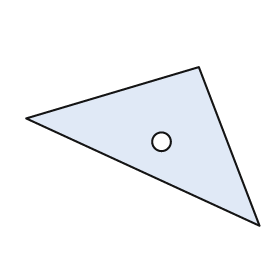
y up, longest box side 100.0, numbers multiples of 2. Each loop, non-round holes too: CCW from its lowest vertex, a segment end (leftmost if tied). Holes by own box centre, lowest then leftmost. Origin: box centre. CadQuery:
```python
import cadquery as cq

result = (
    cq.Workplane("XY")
    .moveTo(50.0, -34.0)
    .lineTo(24.0, 34.0)
    .lineTo(-50.0, 12.0)
    .close()
    .moveTo(8.0, 2.0)
    .circle(4.0)
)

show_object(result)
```